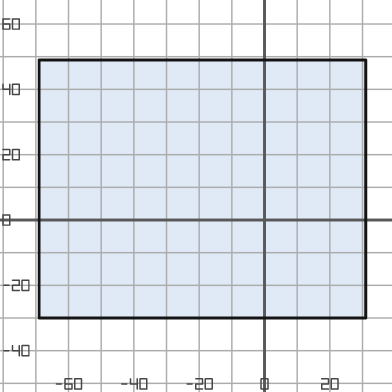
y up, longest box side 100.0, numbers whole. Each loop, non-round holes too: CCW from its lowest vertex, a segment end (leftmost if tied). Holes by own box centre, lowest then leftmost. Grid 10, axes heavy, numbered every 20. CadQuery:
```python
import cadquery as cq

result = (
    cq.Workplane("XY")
    .moveTo(-69.0, -30.0)
    .lineTo(31.0, -30.0)
    .lineTo(31.0, 49.0)
    .lineTo(-69.0, 49.0)
    .close()
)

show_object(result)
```